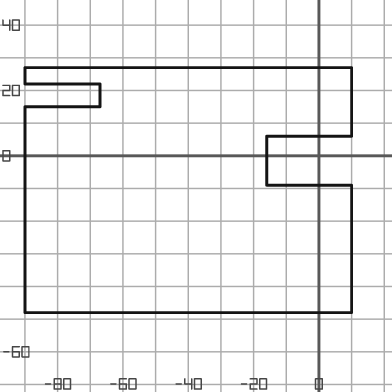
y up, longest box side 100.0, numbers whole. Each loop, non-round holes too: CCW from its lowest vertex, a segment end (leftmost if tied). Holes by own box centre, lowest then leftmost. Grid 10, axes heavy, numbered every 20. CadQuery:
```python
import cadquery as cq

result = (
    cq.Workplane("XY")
    .moveTo(-90.0, -48.0)
    .lineTo(10.0, -48.0)
    .lineTo(10.0, -9.0)
    .lineTo(-16.0, -9.0)
    .lineTo(-16.0, 6.0)
    .lineTo(10.0, 6.0)
    .lineTo(10.0, 27.0)
    .lineTo(-90.0, 27.0)
    .lineTo(-90.0, 22.0)
    .lineTo(-67.0, 22.0)
    .lineTo(-67.0, 15.0)
    .lineTo(-90.0, 15.0)
    .close()
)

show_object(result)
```